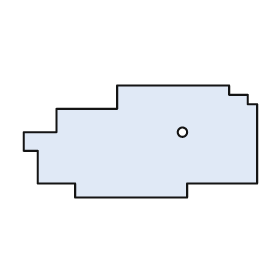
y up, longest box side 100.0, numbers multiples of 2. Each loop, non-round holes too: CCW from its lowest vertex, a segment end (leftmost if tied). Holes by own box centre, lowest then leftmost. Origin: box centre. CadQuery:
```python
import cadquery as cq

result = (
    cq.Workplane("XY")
    .moveTo(-28.0, -24.0)
    .lineTo(20.0, -24.0)
    .lineTo(20.0, -18.0)
    .lineTo(50.0, -18.0)
    .lineTo(50.0, 16.0)
    .lineTo(46.0, 16.0)
    .lineTo(46.0, 20.0)
    .lineTo(38.0, 20.0)
    .lineTo(38.0, 24.0)
    .lineTo(-10.0, 24.0)
    .lineTo(-10.0, 14.0)
    .lineTo(-36.0, 14.0)
    .lineTo(-36.0, 4.0)
    .lineTo(-50.0, 4.0)
    .lineTo(-50.0, -4.0)
    .lineTo(-44.0, -4.0)
    .lineTo(-44.0, -18.0)
    .lineTo(-28.0, -18.0)
    .close()
    .moveTo(18.0, 4.0)
    .circle(2.0)
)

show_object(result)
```